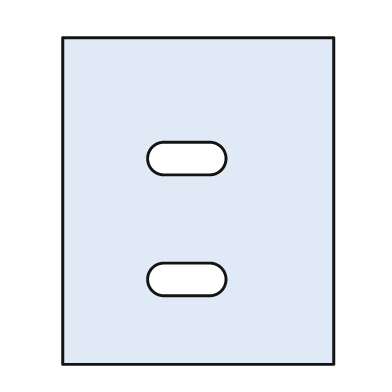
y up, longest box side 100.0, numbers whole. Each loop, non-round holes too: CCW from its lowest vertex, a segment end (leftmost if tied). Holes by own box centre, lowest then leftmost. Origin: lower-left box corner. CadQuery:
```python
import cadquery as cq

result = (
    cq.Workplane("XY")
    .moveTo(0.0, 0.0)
    .lineTo(83.0, 0.0)
    .lineTo(83.0, 100.0)
    .lineTo(0.0, 100.0)
    .close()
    .moveTo(31.0, 21.0)
    .lineTo(45.0, 21.0)
    .threePointArc((50.0, 26.0), (45.0, 31.0))
    .lineTo(31.0, 31.0)
    .threePointArc((26.0, 26.0), (31.0, 21.0))
    .close()
    .moveTo(31.0, 58.0)
    .lineTo(45.0, 58.0)
    .threePointArc((50.0, 63.0), (45.0, 68.0))
    .lineTo(31.0, 68.0)
    .threePointArc((26.0, 63.0), (31.0, 58.0))
    .close()
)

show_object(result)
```